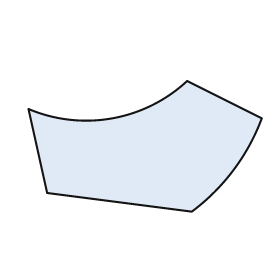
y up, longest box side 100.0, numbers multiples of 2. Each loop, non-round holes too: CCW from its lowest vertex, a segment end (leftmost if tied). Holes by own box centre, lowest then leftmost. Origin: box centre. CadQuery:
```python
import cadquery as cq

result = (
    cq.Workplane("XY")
    .moveTo(20.0, -28.0)
    .threePointArc((38.0, -10.0), (50.0, 12.0))
    .lineTo(18.0, 28.0)
    .threePointArc((-14.0, 12.0), (-50.0, 16.0))
    .lineTo(-42.0, -20.0)
    .close()
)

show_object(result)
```